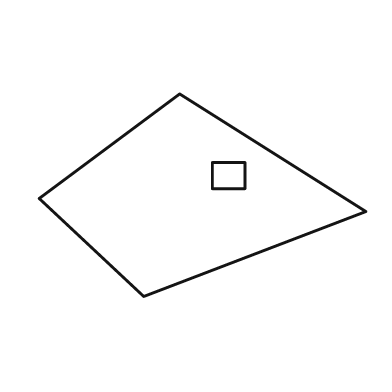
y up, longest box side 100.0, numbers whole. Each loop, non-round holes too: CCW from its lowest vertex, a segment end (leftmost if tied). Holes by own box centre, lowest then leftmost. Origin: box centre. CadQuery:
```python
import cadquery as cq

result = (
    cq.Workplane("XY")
    .moveTo(-18.0, -31.0)
    .lineTo(50.0, -5.0)
    .lineTo(-7.0, 31.0)
    .lineTo(-50.0, -1.0)
    .close()
    .moveTo(3.0, 2.0)
    .lineTo(13.0, 2.0)
    .lineTo(13.0, 10.0)
    .lineTo(3.0, 10.0)
    .close()
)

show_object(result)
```